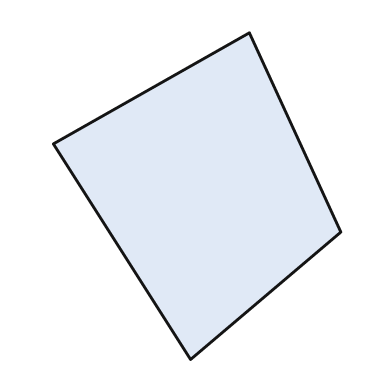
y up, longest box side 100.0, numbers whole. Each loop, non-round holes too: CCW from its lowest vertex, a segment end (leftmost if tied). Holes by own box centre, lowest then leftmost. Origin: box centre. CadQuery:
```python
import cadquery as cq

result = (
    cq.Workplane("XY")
    .moveTo(-2.0, -50.0)
    .lineTo(44.0, -11.0)
    .lineTo(16.0, 50.0)
    .lineTo(-44.0, 16.0)
    .close()
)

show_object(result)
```